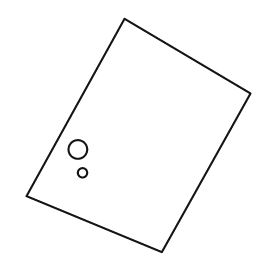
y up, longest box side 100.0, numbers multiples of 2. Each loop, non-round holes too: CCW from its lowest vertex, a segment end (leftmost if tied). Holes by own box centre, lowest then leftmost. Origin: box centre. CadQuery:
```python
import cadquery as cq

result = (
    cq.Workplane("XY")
    .moveTo(10.0, -50.0)
    .lineTo(48.0, 18.0)
    .lineTo(-6.0, 50.0)
    .lineTo(-48.0, -26.0)
    .close()
    .moveTo(-24.0, -16.0)
    .circle(2.0)
    .moveTo(-26.0, -6.0)
    .circle(4.0)
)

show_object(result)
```